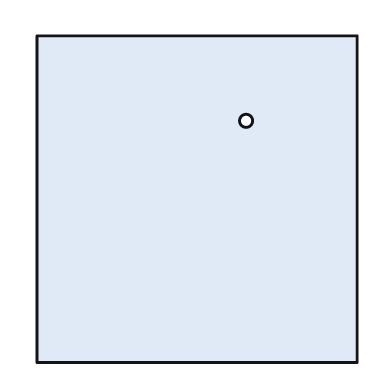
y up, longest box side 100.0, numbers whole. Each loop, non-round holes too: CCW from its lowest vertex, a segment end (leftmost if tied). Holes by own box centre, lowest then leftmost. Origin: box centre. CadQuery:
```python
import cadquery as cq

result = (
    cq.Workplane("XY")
    .moveTo(-49.0, -50.0)
    .lineTo(49.0, -50.0)
    .lineTo(49.0, 50.0)
    .lineTo(-49.0, 50.0)
    .close()
    .moveTo(15.0, 24.0)
    .circle(2.0)
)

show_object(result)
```